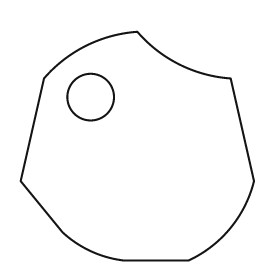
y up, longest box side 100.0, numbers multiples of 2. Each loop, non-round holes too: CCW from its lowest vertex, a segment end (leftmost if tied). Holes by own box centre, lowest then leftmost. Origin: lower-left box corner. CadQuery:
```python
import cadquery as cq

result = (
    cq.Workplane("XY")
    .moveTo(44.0, 0.0)
    .lineTo(72.0, 0.0)
    .threePointArc((90.0, 14.0), (100.0, 34.0))
    .lineTo(90.0, 78.0)
    .threePointArc((68.0, 84.0), (50.0, 98.0))
    .threePointArc((28.0, 92.0), (10.0, 78.0))
    .lineTo(0.0, 34.0)
    .lineTo(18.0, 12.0)
    .threePointArc((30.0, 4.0), (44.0, 0.0))
    .close()
    .moveTo(30.0, 70.0)
    .circle(10.0)
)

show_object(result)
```